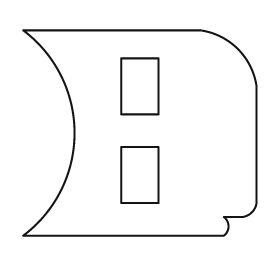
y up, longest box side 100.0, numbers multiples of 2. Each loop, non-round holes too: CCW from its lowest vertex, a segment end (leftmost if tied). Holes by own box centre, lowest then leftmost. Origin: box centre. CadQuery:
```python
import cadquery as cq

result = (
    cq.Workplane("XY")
    .moveTo(-50.0, -44.0)
    .lineTo(36.0, -44.0)
    .threePointArc((38.0, -40.0), (36.0, -36.0))
    .lineTo(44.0, -36.0)
    .threePointArc((48.0, -34.0), (50.0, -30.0))
    .lineTo(50.0, 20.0)
    .threePointArc((42.0, 36.0), (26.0, 44.0))
    .lineTo(-50.0, 44.0)
    .threePointArc((-28.0, 0.0), (-50.0, -44.0))
    .close()
    .moveTo(-8.0, -30.0)
    .lineTo(8.0, -30.0)
    .lineTo(8.0, -6.0)
    .lineTo(-8.0, -6.0)
    .close()
    .moveTo(-8.0, 8.0)
    .lineTo(8.0, 8.0)
    .lineTo(8.0, 32.0)
    .lineTo(-8.0, 32.0)
    .close()
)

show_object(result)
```